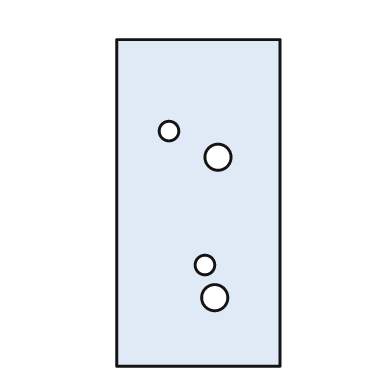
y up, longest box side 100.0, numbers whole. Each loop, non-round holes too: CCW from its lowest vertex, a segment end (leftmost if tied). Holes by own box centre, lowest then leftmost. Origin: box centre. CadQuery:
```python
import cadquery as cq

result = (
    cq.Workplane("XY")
    .moveTo(-25.0, -50.0)
    .lineTo(25.0, -50.0)
    .lineTo(25.0, 50.0)
    .lineTo(-25.0, 50.0)
    .close()
    .moveTo(5.0, -29.0)
    .circle(4.0)
    .moveTo(2.0, -19.0)
    .circle(3.0)
    .moveTo(6.0, 14.0)
    .circle(4.0)
    .moveTo(-9.0, 22.0)
    .circle(3.0)
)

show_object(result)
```